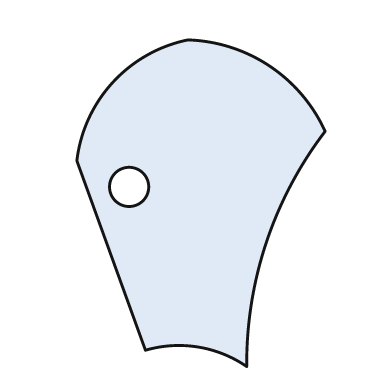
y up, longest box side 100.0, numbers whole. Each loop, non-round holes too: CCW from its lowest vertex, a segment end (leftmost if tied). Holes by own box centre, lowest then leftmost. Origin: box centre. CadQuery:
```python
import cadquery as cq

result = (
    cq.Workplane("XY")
    .moveTo(14.0, -50.0)
    .threePointArc((20.0, -12.0), (38.0, 22.0))
    .threePointArc((21.0, 42.0), (-4.0, 50.0))
    .threePointArc((-27.0, 37.0), (-38.0, 13.0))
    .lineTo(-17.0, -45.0)
    .threePointArc((-1.0, -44.0), (14.0, -50.0))
    .close()
    .moveTo(-22.0, 5.0)
    .circle(6.0)
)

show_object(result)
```